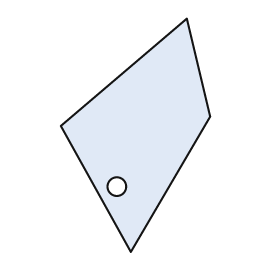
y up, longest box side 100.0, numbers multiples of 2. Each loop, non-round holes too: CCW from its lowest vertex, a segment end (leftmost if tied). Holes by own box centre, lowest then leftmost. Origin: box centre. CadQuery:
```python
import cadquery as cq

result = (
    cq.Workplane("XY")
    .moveTo(-2.0, -50.0)
    .lineTo(32.0, 8.0)
    .lineTo(22.0, 50.0)
    .lineTo(-32.0, 4.0)
    .close()
    .moveTo(-8.0, -22.0)
    .circle(4.0)
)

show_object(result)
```